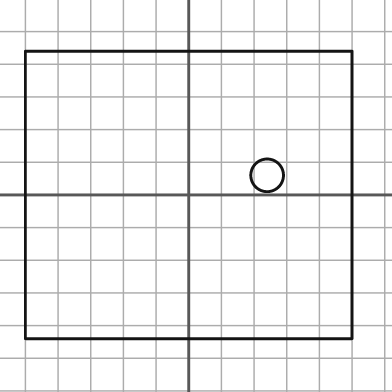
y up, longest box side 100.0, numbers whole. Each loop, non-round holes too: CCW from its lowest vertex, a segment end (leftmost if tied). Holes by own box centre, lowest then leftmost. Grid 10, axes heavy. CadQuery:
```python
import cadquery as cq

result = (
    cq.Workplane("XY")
    .moveTo(-50.0, -44.0)
    .lineTo(50.0, -44.0)
    .lineTo(50.0, 44.0)
    .lineTo(-50.0, 44.0)
    .close()
    .moveTo(24.0, 6.0)
    .circle(5.0)
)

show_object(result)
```